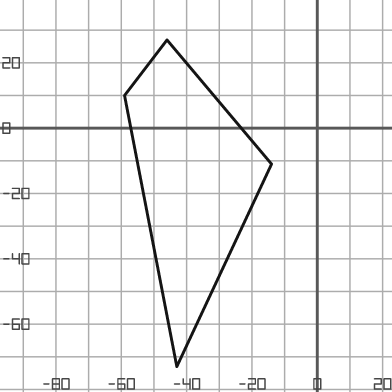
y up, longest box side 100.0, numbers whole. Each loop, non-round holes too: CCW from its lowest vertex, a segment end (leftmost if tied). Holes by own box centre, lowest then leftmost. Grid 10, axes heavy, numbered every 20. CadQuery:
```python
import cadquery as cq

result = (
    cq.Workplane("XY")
    .moveTo(-43.0, -73.0)
    .lineTo(-14.0, -11.0)
    .lineTo(-46.0, 27.0)
    .lineTo(-59.0, 10.0)
    .close()
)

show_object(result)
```